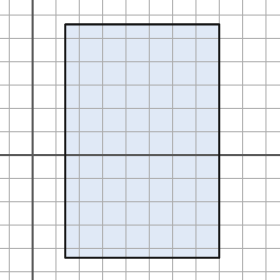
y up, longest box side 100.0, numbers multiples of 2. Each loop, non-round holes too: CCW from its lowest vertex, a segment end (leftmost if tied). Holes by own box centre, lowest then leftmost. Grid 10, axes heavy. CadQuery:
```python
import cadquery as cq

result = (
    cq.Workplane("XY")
    .moveTo(14.0, -44.0)
    .lineTo(80.0, -44.0)
    .lineTo(80.0, 56.0)
    .lineTo(14.0, 56.0)
    .close()
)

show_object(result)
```